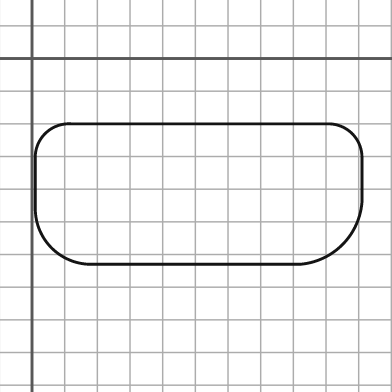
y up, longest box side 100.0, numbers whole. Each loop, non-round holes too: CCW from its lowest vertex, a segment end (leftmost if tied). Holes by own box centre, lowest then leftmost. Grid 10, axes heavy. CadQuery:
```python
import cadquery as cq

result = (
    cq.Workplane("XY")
    .moveTo(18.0, -63.0)
    .lineTo(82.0, -63.0)
    .threePointArc((95.0, -57.0), (101.0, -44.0))
    .lineTo(101.0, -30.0)
    .threePointArc((98.0, -23.0), (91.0, -20.0))
    .lineTo(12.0, -20.0)
    .threePointArc((4.0, -23.0), (1.0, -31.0))
    .lineTo(1.0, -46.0)
    .threePointArc((6.0, -58.0), (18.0, -63.0))
    .close()
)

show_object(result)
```